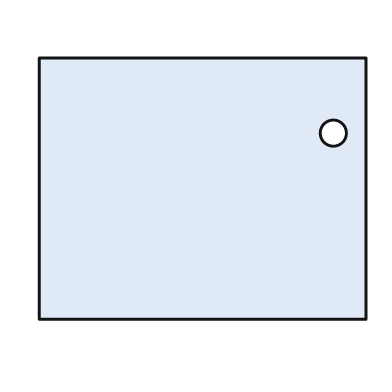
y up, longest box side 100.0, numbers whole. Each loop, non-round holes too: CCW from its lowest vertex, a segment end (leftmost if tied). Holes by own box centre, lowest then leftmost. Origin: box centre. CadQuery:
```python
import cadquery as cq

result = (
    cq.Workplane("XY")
    .moveTo(-50.0, -40.0)
    .lineTo(50.0, -40.0)
    .lineTo(50.0, 40.0)
    .lineTo(-50.0, 40.0)
    .close()
    .moveTo(40.0, 17.0)
    .circle(4.0)
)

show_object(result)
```